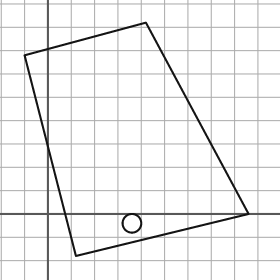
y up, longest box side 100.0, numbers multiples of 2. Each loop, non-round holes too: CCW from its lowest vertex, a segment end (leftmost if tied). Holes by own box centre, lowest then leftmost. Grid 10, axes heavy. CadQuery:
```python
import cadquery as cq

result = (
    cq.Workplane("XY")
    .moveTo(12.0, -18.0)
    .lineTo(86.0, 0.0)
    .lineTo(42.0, 82.0)
    .lineTo(-10.0, 68.0)
    .close()
    .moveTo(36.0, -4.0)
    .circle(4.0)
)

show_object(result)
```